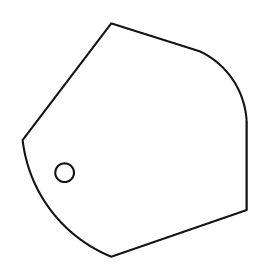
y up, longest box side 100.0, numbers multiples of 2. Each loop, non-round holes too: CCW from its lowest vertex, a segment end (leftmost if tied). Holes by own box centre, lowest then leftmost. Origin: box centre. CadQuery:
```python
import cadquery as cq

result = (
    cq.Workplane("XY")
    .moveTo(-10.0, -50.0)
    .lineTo(48.0, -30.0)
    .lineTo(48.0, 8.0)
    .threePointArc((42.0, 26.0), (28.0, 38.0))
    .lineTo(-10.0, 50.0)
    .lineTo(-48.0, 0.0)
    .threePointArc((-36.0, -30.0), (-10.0, -50.0))
    .close()
    .moveTo(-30.0, -14.0)
    .circle(4.0)
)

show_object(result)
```